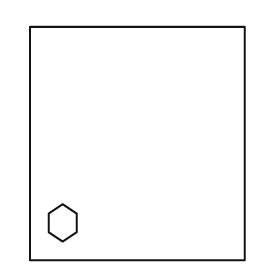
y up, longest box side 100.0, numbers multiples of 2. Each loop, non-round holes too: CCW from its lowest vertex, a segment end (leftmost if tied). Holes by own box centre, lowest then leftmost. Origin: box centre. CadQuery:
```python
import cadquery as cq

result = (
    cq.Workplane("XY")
    .moveTo(-46.0, -50.0)
    .lineTo(46.0, -50.0)
    .lineTo(46.0, 50.0)
    .lineTo(-46.0, 50.0)
    .close()
    .moveTo(-32.0, -42.0)
    .lineTo(-26.0, -38.0)
    .lineTo(-26.0, -30.0)
    .lineTo(-32.0, -26.0)
    .lineTo(-38.0, -30.0)
    .lineTo(-38.0, -38.0)
    .close()
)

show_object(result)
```